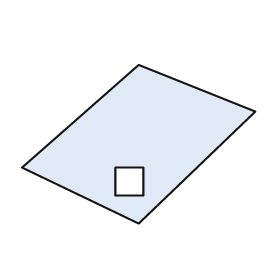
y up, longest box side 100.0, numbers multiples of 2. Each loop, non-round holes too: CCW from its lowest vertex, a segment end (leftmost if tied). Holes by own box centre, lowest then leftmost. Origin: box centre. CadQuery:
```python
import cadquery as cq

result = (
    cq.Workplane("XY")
    .moveTo(0.0, -34.0)
    .lineTo(50.0, 14.0)
    .lineTo(0.0, 34.0)
    .lineTo(-50.0, -10.0)
    .close()
    .moveTo(-10.0, -22.0)
    .lineTo(2.0, -22.0)
    .lineTo(2.0, -10.0)
    .lineTo(-10.0, -10.0)
    .close()
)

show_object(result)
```